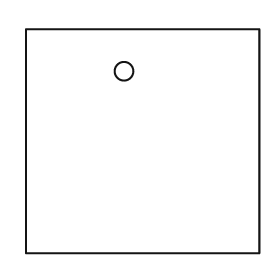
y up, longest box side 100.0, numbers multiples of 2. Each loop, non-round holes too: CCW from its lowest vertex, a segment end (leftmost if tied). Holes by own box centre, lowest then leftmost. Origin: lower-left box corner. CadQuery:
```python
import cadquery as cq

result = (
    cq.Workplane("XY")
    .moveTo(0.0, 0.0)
    .lineTo(100.0, 0.0)
    .lineTo(100.0, 96.0)
    .lineTo(0.0, 96.0)
    .close()
    .moveTo(42.0, 78.0)
    .circle(4.0)
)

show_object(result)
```